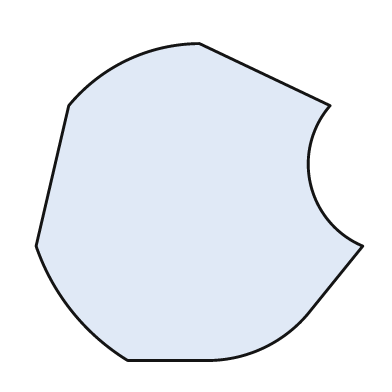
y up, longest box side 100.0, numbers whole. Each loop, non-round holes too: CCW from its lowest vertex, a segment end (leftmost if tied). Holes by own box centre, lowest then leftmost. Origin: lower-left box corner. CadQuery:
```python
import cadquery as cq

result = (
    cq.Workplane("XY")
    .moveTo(28.0, 0.0)
    .lineTo(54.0, 0.0)
    .threePointArc((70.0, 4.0), (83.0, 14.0))
    .lineTo(100.0, 35.0)
    .threePointArc((84.0, 54.0), (90.0, 78.0))
    .lineTo(50.0, 97.0)
    .threePointArc((28.0, 92.0), (10.0, 78.0))
    .lineTo(0.0, 35.0)
    .threePointArc((11.0, 15.0), (28.0, 0.0))
    .close()
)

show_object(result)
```